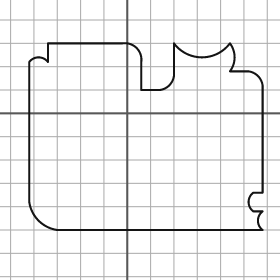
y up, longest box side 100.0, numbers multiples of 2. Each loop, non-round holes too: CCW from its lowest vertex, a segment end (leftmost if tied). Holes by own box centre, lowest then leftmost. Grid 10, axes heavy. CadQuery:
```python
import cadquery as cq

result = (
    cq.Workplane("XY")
    .moveTo(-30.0, -50.0)
    .lineTo(58.0, -50.0)
    .threePointArc((56.0, -46.0), (58.0, -42.0))
    .lineTo(54.0, -42.0)
    .threePointArc((52.0, -38.0), (54.0, -34.0))
    .lineTo(58.0, -34.0)
    .lineTo(58.0, 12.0)
    .threePointArc((56.0, 16.0), (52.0, 18.0))
    .lineTo(44.0, 18.0)
    .threePointArc((46.0, 24.0), (44.0, 30.0))
    .threePointArc((32.0, 24.0), (20.0, 30.0))
    .lineTo(20.0, 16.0)
    .threePointArc((18.0, 12.0), (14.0, 10.0))
    .lineTo(6.0, 10.0)
    .lineTo(6.0, 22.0)
    .threePointArc((4.0, 28.0), (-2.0, 30.0))
    .lineTo(-34.0, 30.0)
    .lineTo(-34.0, 22.0)
    .threePointArc((-38.0, 24.0), (-42.0, 22.0))
    .lineTo(-42.0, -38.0)
    .threePointArc((-38.0, -46.0), (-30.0, -50.0))
    .close()
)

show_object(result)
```